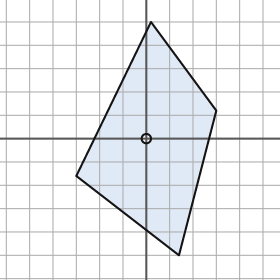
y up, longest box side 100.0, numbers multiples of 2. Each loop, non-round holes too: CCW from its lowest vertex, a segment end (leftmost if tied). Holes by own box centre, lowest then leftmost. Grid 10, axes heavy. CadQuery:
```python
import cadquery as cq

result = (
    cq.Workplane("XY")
    .moveTo(14.0, -50.0)
    .lineTo(30.0, 12.0)
    .lineTo(2.0, 50.0)
    .lineTo(-30.0, -16.0)
    .close()
    .moveTo(0.0, 0.0)
    .circle(2.0)
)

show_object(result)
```